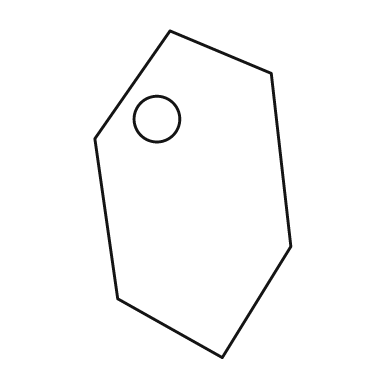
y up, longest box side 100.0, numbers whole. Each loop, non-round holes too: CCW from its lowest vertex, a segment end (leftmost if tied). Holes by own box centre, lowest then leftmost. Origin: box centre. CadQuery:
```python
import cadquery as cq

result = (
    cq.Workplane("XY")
    .moveTo(9.0, -50.0)
    .lineTo(30.0, -16.0)
    .lineTo(24.0, 37.0)
    .lineTo(-7.0, 50.0)
    .lineTo(-30.0, 17.0)
    .lineTo(-23.0, -32.0)
    .close()
    .moveTo(-11.0, 23.0)
    .circle(7.0)
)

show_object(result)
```